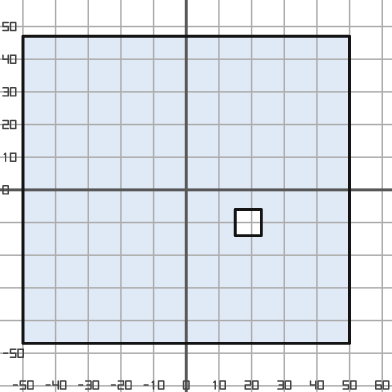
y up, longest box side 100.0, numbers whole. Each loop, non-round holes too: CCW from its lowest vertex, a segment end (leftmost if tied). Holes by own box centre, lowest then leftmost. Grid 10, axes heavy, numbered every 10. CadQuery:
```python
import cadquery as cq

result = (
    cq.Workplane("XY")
    .moveTo(-50.0, -47.0)
    .lineTo(50.0, -47.0)
    .lineTo(50.0, 47.0)
    .lineTo(-50.0, 47.0)
    .close()
    .moveTo(15.0, -14.0)
    .lineTo(23.0, -14.0)
    .lineTo(23.0, -6.0)
    .lineTo(15.0, -6.0)
    .close()
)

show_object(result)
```